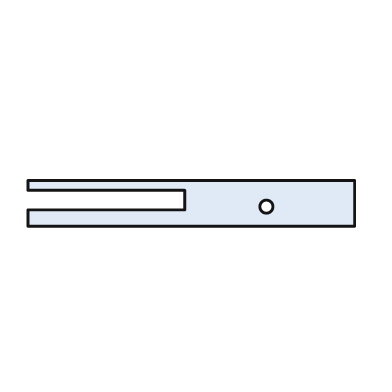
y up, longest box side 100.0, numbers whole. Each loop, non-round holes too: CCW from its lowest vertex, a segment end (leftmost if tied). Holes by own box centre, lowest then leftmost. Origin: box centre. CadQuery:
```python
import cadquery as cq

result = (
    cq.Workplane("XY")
    .moveTo(-50.0, -7.0)
    .lineTo(50.0, -7.0)
    .lineTo(50.0, 7.0)
    .lineTo(-50.0, 7.0)
    .lineTo(-50.0, 4.0)
    .lineTo(-2.0, 4.0)
    .lineTo(-2.0, -2.0)
    .lineTo(-50.0, -2.0)
    .close()
    .moveTo(23.0, -1.0)
    .circle(2.0)
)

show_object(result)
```